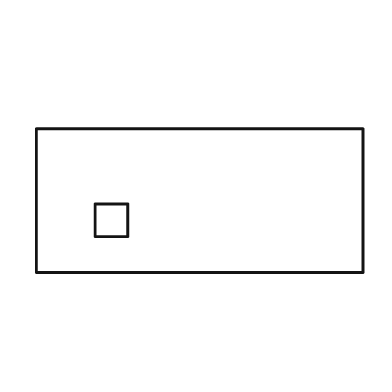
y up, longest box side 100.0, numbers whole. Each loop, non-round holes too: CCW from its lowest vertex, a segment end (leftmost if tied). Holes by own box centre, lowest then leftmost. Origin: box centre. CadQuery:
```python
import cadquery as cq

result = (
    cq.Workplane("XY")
    .moveTo(-50.0, -22.0)
    .lineTo(50.0, -22.0)
    .lineTo(50.0, 22.0)
    .lineTo(-50.0, 22.0)
    .close()
    .moveTo(-32.0, -11.0)
    .lineTo(-22.0, -11.0)
    .lineTo(-22.0, -1.0)
    .lineTo(-32.0, -1.0)
    .close()
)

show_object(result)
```